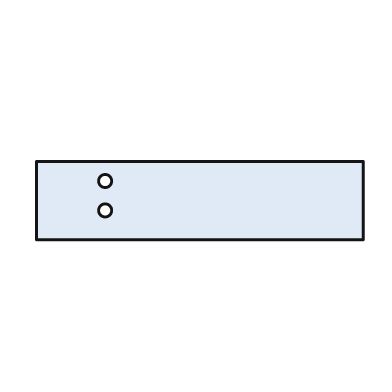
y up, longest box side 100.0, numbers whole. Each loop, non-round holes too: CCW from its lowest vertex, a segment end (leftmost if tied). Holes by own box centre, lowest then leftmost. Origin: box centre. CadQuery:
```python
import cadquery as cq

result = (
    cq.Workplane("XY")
    .moveTo(-50.0, -12.0)
    .lineTo(50.0, -12.0)
    .lineTo(50.0, 12.0)
    .lineTo(-50.0, 12.0)
    .close()
    .moveTo(-29.0, -3.0)
    .circle(2.0)
    .moveTo(-29.0, 6.0)
    .circle(2.0)
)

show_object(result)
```